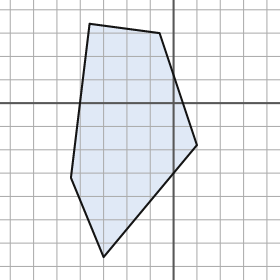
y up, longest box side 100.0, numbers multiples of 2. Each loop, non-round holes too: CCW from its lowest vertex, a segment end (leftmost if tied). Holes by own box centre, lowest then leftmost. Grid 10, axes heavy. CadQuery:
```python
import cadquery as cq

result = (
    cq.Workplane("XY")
    .moveTo(-30.0, -66.0)
    .lineTo(10.0, -18.0)
    .lineTo(-6.0, 30.0)
    .lineTo(-36.0, 34.0)
    .lineTo(-44.0, -32.0)
    .close()
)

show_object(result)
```